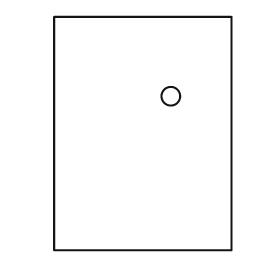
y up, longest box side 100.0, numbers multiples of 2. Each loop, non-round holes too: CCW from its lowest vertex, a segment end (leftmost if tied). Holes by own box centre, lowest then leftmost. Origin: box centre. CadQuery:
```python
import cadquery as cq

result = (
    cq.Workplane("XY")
    .moveTo(-38.0, -50.0)
    .lineTo(38.0, -50.0)
    .lineTo(38.0, 50.0)
    .lineTo(-38.0, 50.0)
    .close()
    .moveTo(12.0, 16.0)
    .circle(4.0)
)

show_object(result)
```